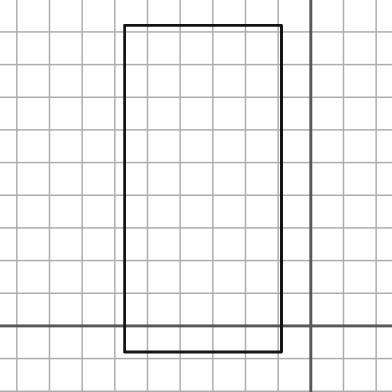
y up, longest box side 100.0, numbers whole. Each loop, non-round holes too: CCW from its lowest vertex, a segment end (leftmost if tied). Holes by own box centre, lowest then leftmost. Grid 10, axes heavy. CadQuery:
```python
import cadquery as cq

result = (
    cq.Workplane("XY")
    .moveTo(-57.0, -8.0)
    .lineTo(-9.0, -8.0)
    .lineTo(-9.0, 92.0)
    .lineTo(-57.0, 92.0)
    .close()
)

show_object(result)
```